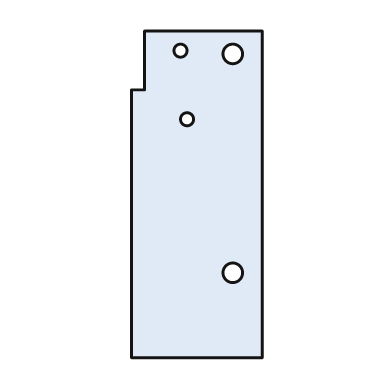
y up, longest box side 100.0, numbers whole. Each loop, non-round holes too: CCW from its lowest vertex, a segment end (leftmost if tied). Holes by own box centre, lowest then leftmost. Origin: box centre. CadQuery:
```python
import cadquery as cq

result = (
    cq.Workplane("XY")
    .moveTo(-20.0, -50.0)
    .lineTo(20.0, -50.0)
    .lineTo(20.0, 50.0)
    .lineTo(-16.0, 50.0)
    .lineTo(-16.0, 32.0)
    .lineTo(-20.0, 32.0)
    .close()
    .moveTo(11.0, -24.0)
    .circle(3.0)
    .moveTo(-3.0, 23.0)
    .circle(2.0)
    .moveTo(11.0, 43.0)
    .circle(3.0)
    .moveTo(-5.0, 44.0)
    .circle(2.0)
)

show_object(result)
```